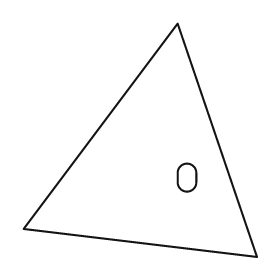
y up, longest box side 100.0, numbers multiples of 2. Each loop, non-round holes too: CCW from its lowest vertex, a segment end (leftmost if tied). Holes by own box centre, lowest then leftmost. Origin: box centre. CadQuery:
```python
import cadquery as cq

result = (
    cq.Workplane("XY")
    .moveTo(50.0, -50.0)
    .lineTo(16.0, 50.0)
    .lineTo(-50.0, -38.0)
    .close()
    .moveTo(16.0, -18.0)
    .threePointArc((20.0, -22.0), (24.0, -18.0))
    .lineTo(24.0, -14.0)
    .threePointArc((20.0, -10.0), (16.0, -14.0))
    .close()
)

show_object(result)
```